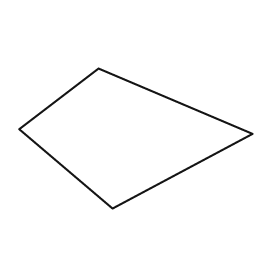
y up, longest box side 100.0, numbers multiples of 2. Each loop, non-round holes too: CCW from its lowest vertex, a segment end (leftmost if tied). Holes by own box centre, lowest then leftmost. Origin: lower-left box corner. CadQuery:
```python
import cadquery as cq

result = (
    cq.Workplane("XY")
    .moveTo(40.0, 0.0)
    .lineTo(100.0, 32.0)
    .lineTo(34.0, 60.0)
    .lineTo(0.0, 34.0)
    .close()
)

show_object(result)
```